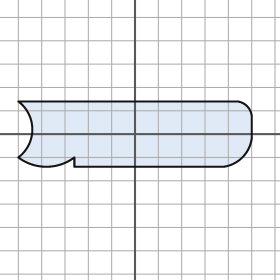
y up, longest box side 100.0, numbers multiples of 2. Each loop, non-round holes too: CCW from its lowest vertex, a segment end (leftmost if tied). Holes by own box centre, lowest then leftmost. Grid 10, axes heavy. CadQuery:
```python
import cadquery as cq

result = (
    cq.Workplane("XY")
    .moveTo(-26.0, -14.0)
    .lineTo(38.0, -14.0)
    .threePointArc((46.0, -10.0), (50.0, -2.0))
    .lineTo(50.0, 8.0)
    .threePointArc((48.0, 12.0), (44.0, 14.0))
    .lineTo(-50.0, 14.0)
    .threePointArc((-44.0, 2.0), (-50.0, -10.0))
    .threePointArc((-38.0, -14.0), (-26.0, -10.0))
    .close()
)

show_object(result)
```